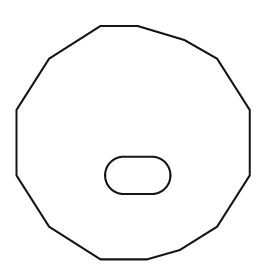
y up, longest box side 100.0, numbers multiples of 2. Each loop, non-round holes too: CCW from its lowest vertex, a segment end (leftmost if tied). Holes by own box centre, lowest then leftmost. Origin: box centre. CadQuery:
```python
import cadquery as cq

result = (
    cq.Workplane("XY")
    .moveTo(-14.0, -50.0)
    .lineTo(6.0, -50.0)
    .lineTo(20.0, -46.0)
    .lineTo(36.0, -36.0)
    .lineTo(50.0, -14.0)
    .lineTo(50.0, 14.0)
    .lineTo(36.0, 36.0)
    .lineTo(22.0, 44.0)
    .lineTo(2.0, 50.0)
    .lineTo(-14.0, 50.0)
    .lineTo(-36.0, 36.0)
    .lineTo(-50.0, 14.0)
    .lineTo(-50.0, -14.0)
    .lineTo(-36.0, -36.0)
    .close()
    .moveTo(-4.0, -22.0)
    .lineTo(8.0, -22.0)
    .threePointArc((16.0, -14.0), (8.0, -6.0))
    .lineTo(-4.0, -6.0)
    .threePointArc((-12.0, -14.0), (-4.0, -22.0))
    .close()
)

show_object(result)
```